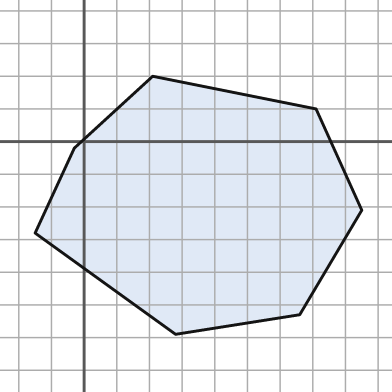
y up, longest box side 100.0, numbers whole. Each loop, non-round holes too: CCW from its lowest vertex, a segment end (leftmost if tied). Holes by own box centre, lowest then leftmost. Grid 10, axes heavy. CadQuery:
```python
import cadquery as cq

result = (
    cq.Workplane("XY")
    .moveTo(28.0, -59.0)
    .lineTo(66.0, -53.0)
    .lineTo(85.0, -21.0)
    .lineTo(71.0, 10.0)
    .lineTo(21.0, 20.0)
    .lineTo(-3.0, -2.0)
    .lineTo(-15.0, -28.0)
    .close()
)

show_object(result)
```